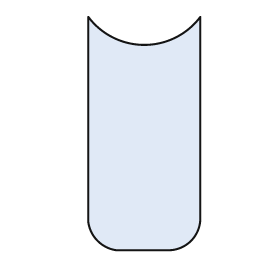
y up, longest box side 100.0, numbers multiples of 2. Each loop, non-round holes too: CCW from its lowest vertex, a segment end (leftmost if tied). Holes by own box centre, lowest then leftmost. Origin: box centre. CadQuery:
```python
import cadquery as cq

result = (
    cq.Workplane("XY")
    .moveTo(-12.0, -50.0)
    .lineTo(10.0, -50.0)
    .threePointArc((20.0, -46.0), (24.0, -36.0))
    .lineTo(24.0, 50.0)
    .threePointArc((0.0, 38.0), (-24.0, 50.0))
    .lineTo(-24.0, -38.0)
    .threePointArc((-20.0, -46.0), (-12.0, -50.0))
    .close()
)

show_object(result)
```